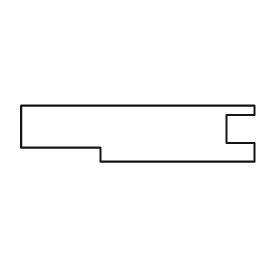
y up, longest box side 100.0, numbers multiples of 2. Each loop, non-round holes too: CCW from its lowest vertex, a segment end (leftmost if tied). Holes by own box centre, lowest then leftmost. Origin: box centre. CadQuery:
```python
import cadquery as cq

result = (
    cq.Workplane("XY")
    .moveTo(-16.0, -12.0)
    .lineTo(50.0, -12.0)
    .lineTo(50.0, -4.0)
    .lineTo(38.0, -4.0)
    .lineTo(38.0, 8.0)
    .lineTo(50.0, 8.0)
    .lineTo(50.0, 12.0)
    .lineTo(-50.0, 12.0)
    .lineTo(-50.0, -6.0)
    .lineTo(-16.0, -6.0)
    .close()
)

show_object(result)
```